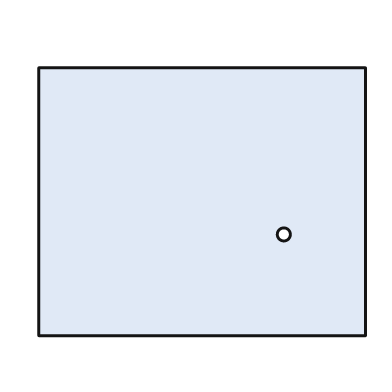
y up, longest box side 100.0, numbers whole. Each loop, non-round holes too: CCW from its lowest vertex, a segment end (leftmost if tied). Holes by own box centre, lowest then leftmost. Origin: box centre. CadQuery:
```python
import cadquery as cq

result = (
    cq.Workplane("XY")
    .moveTo(-50.0, -41.0)
    .lineTo(50.0, -41.0)
    .lineTo(50.0, 41.0)
    .lineTo(-50.0, 41.0)
    .close()
    .moveTo(25.0, -10.0)
    .circle(2.0)
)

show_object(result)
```